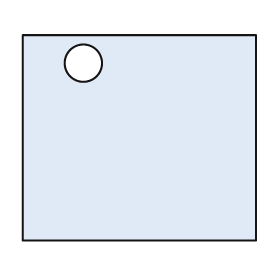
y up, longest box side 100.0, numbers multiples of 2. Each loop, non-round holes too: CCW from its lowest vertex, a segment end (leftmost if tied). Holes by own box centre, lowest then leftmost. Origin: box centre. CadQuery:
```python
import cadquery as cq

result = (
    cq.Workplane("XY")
    .moveTo(-50.0, -44.0)
    .lineTo(50.0, -44.0)
    .lineTo(50.0, 44.0)
    .lineTo(-50.0, 44.0)
    .close()
    .moveTo(-24.0, 32.0)
    .circle(8.0)
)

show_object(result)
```